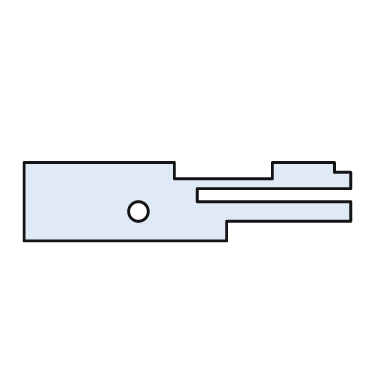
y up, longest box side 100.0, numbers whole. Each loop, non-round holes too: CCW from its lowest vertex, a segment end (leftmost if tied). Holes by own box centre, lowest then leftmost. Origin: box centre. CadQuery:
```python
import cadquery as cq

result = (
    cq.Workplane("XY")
    .moveTo(-50.0, -12.0)
    .lineTo(12.0, -12.0)
    .lineTo(12.0, -6.0)
    .lineTo(50.0, -6.0)
    .lineTo(50.0, 0.0)
    .lineTo(3.0, 0.0)
    .lineTo(3.0, 4.0)
    .lineTo(50.0, 4.0)
    .lineTo(50.0, 9.0)
    .lineTo(45.0, 9.0)
    .lineTo(45.0, 12.0)
    .lineTo(26.0, 12.0)
    .lineTo(26.0, 7.0)
    .lineTo(-4.0, 7.0)
    .lineTo(-4.0, 12.0)
    .lineTo(-50.0, 12.0)
    .close()
    .moveTo(-15.0, -3.0)
    .circle(3.0)
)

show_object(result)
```